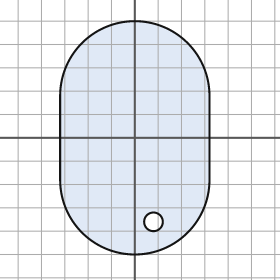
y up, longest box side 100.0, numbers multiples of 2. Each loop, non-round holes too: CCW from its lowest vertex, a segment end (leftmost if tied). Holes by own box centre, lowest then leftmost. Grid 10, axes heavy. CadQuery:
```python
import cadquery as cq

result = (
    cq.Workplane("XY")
    .moveTo(-32.0, -18.0)
    .threePointArc((0.0, -50.0), (32.0, -18.0))
    .lineTo(32.0, 18.0)
    .threePointArc((0.0, 50.0), (-32.0, 18.0))
    .close()
    .moveTo(8.0, -36.0)
    .circle(4.0)
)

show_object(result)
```